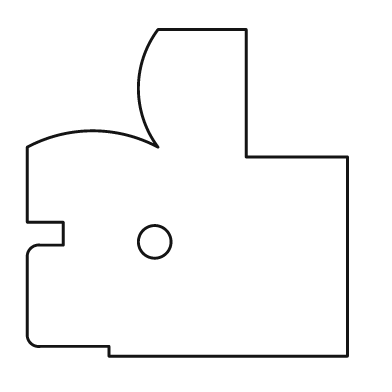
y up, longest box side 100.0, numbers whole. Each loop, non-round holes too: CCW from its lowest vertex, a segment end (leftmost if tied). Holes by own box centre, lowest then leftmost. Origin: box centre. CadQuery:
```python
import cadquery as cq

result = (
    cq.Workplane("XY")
    .moveTo(-24.0, -50.0)
    .lineTo(49.0, -50.0)
    .lineTo(49.0, 11.0)
    .lineTo(18.0, 11.0)
    .lineTo(18.0, 50.0)
    .lineTo(-9.0, 50.0)
    .threePointArc((-15.0, 32.0), (-9.0, 14.0))
    .threePointArc((-29.0, 19.0), (-49.0, 14.0))
    .lineTo(-49.0, -9.0)
    .lineTo(-38.0, -9.0)
    .lineTo(-38.0, -16.0)
    .lineTo(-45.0, -16.0)
    .threePointArc((-48.0, -17.0), (-49.0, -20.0))
    .lineTo(-49.0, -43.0)
    .threePointArc((-48.0, -46.0), (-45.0, -47.0))
    .lineTo(-24.0, -47.0)
    .close()
    .moveTo(-10.0, -15.0)
    .circle(5.0)
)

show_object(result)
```